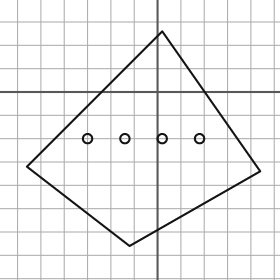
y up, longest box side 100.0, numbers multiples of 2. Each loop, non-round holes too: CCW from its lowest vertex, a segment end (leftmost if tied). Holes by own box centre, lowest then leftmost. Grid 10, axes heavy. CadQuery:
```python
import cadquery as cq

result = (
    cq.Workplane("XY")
    .moveTo(-12.0, -66.0)
    .lineTo(44.0, -34.0)
    .lineTo(2.0, 26.0)
    .lineTo(-56.0, -32.0)
    .close()
    .moveTo(-30.0, -20.0)
    .circle(2.0)
    .moveTo(-14.0, -20.0)
    .circle(2.0)
    .moveTo(2.0, -20.0)
    .circle(2.0)
    .moveTo(18.0, -20.0)
    .circle(2.0)
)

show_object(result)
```